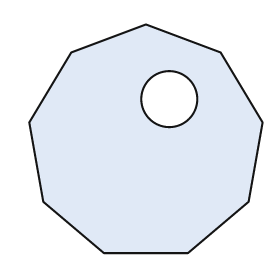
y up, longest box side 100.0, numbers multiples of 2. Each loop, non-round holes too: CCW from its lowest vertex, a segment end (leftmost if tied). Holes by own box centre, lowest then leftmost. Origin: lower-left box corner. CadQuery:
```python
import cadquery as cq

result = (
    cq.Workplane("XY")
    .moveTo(32.0, 0.0)
    .lineTo(68.0, 0.0)
    .lineTo(94.0, 22.0)
    .lineTo(100.0, 56.0)
    .lineTo(82.0, 86.0)
    .lineTo(50.0, 98.0)
    .lineTo(18.0, 86.0)
    .lineTo(0.0, 56.0)
    .lineTo(6.0, 22.0)
    .close()
    .moveTo(60.0, 66.0)
    .circle(12.0)
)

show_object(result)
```